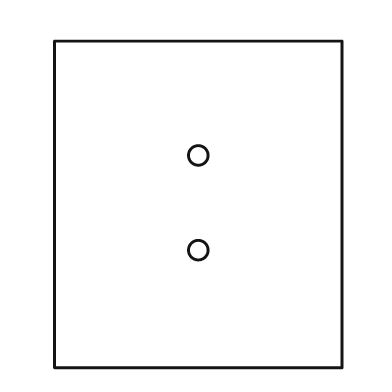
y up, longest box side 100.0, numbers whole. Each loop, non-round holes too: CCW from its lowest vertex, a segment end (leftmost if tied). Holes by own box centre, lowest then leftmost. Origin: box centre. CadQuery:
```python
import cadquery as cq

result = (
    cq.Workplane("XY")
    .moveTo(-44.0, -50.0)
    .lineTo(44.0, -50.0)
    .lineTo(44.0, 50.0)
    .lineTo(-44.0, 50.0)
    .close()
    .moveTo(0.0, -14.0)
    .circle(3.0)
    .moveTo(0.0, 15.0)
    .circle(3.0)
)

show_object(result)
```